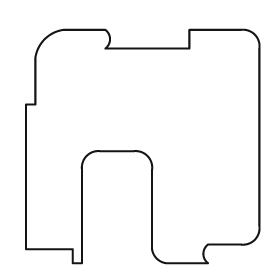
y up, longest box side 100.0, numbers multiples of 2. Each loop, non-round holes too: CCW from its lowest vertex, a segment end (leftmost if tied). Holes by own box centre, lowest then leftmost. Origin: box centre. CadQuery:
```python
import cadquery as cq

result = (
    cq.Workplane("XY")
    .moveTo(-30.0, -50.0)
    .lineTo(-26.0, -50.0)
    .lineTo(-26.0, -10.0)
    .threePointArc((-24.0, -4.0), (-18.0, -2.0))
    .lineTo(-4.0, -2.0)
    .threePointArc((2.0, -4.0), (4.0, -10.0))
    .lineTo(4.0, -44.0)
    .threePointArc((6.0, -48.0), (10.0, -50.0))
    .lineTo(28.0, -50.0)
    .threePointArc((26.0, -46.0), (28.0, -42.0))
    .lineTo(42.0, -42.0)
    .threePointArc((48.0, -40.0), (50.0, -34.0))
    .lineTo(50.0, 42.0)
    .threePointArc((48.0, 48.0), (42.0, 50.0))
    .lineTo(20.0, 50.0)
    .lineTo(20.0, 42.0)
    .lineTo(-16.0, 42.0)
    .threePointArc((-14.0, 46.0), (-16.0, 50.0))
    .lineTo(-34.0, 50.0)
    .threePointArc((-42.0, 46.0), (-46.0, 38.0))
    .lineTo(-46.0, 18.0)
    .lineTo(-50.0, 18.0)
    .lineTo(-50.0, -44.0)
    .lineTo(-30.0, -44.0)
    .close()
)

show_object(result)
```